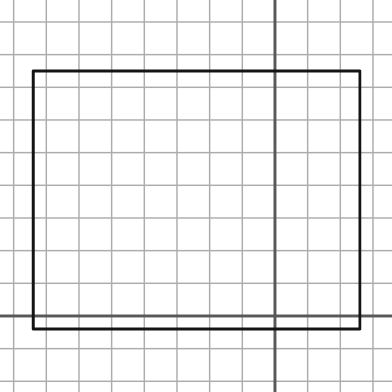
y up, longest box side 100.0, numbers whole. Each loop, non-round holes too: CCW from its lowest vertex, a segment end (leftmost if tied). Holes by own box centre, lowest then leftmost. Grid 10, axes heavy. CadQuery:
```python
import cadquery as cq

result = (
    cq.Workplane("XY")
    .moveTo(-74.0, -4.0)
    .lineTo(26.0, -4.0)
    .lineTo(26.0, 75.0)
    .lineTo(-74.0, 75.0)
    .close()
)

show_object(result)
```